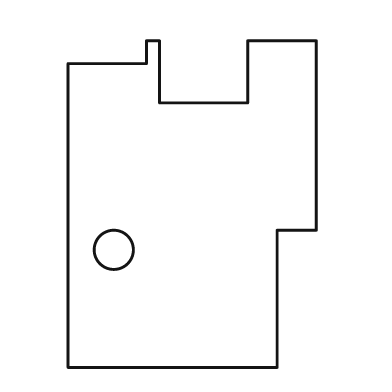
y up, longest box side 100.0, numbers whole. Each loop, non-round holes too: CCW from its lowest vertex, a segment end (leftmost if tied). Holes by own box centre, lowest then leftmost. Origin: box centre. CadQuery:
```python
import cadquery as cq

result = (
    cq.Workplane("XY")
    .moveTo(-38.0, -50.0)
    .lineTo(26.0, -50.0)
    .lineTo(26.0, -8.0)
    .lineTo(38.0, -8.0)
    .lineTo(38.0, 50.0)
    .lineTo(17.0, 50.0)
    .lineTo(17.0, 31.0)
    .lineTo(-10.0, 31.0)
    .lineTo(-10.0, 50.0)
    .lineTo(-14.0, 50.0)
    .lineTo(-14.0, 43.0)
    .lineTo(-38.0, 43.0)
    .close()
    .moveTo(-24.0, -14.0)
    .circle(6.0)
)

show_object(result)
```